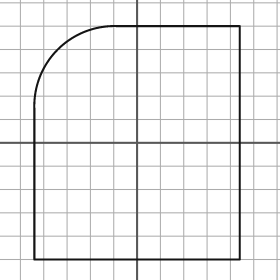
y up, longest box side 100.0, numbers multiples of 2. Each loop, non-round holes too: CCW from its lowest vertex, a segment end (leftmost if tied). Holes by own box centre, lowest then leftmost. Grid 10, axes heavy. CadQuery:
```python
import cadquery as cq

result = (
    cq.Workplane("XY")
    .moveTo(-44.0, -50.0)
    .lineTo(44.0, -50.0)
    .lineTo(44.0, 50.0)
    .lineTo(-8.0, 50.0)
    .threePointArc((-34.0, 40.0), (-44.0, 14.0))
    .close()
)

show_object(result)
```